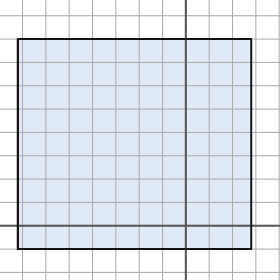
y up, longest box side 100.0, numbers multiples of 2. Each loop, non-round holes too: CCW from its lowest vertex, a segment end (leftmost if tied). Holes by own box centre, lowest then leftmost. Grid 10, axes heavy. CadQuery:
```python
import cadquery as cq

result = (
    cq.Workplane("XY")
    .moveTo(-72.0, -10.0)
    .lineTo(28.0, -10.0)
    .lineTo(28.0, 80.0)
    .lineTo(-72.0, 80.0)
    .close()
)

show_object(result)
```